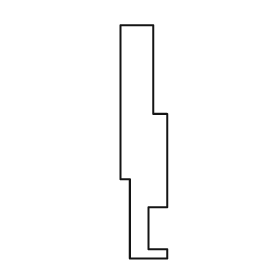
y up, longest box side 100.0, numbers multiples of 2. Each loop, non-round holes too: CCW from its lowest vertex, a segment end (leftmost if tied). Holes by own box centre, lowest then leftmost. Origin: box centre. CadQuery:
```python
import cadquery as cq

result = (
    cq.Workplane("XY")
    .moveTo(-6.0, -50.0)
    .lineTo(10.0, -50.0)
    .lineTo(10.0, -46.0)
    .lineTo(2.0, -46.0)
    .lineTo(2.0, -28.0)
    .lineTo(10.0, -28.0)
    .lineTo(10.0, 12.0)
    .lineTo(4.0, 12.0)
    .lineTo(4.0, 50.0)
    .lineTo(-10.0, 50.0)
    .lineTo(-10.0, -16.0)
    .lineTo(-6.0, -16.0)
    .close()
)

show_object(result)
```